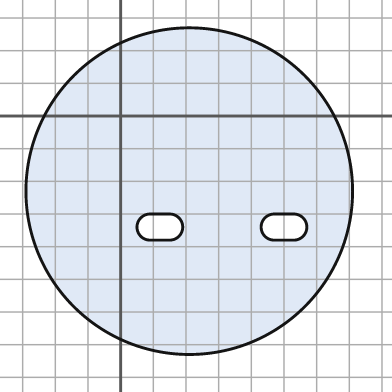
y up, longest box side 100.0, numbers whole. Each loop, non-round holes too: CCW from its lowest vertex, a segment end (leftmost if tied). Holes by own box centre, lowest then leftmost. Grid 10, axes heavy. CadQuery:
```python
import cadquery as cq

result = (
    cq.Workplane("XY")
    .moveTo(21.0, -23.0)
    .circle(50.0)
    .moveTo(9.0, -38.0)
    .lineTo(15.0, -38.0)
    .threePointArc((19.0, -34.0), (15.0, -30.0))
    .lineTo(9.0, -30.0)
    .threePointArc((5.0, -34.0), (9.0, -38.0))
    .close()
    .moveTo(47.0, -38.0)
    .lineTo(53.0, -38.0)
    .threePointArc((57.0, -34.0), (53.0, -30.0))
    .lineTo(47.0, -30.0)
    .threePointArc((43.0, -34.0), (47.0, -38.0))
    .close()
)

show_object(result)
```